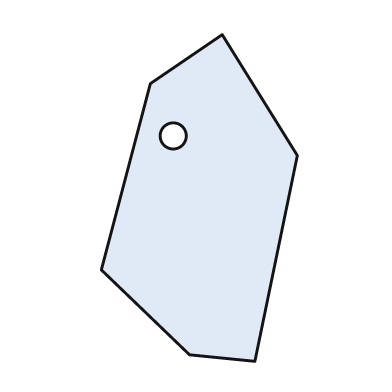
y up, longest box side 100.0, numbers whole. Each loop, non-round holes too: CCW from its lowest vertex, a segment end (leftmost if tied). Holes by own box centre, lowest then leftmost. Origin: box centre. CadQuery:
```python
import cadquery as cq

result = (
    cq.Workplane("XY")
    .moveTo(17.0, -50.0)
    .lineTo(30.0, 13.0)
    .lineTo(7.0, 50.0)
    .lineTo(-15.0, 35.0)
    .lineTo(-30.0, -22.0)
    .lineTo(-3.0, -48.0)
    .close()
    .moveTo(-8.0, 19.0)
    .circle(4.0)
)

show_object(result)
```